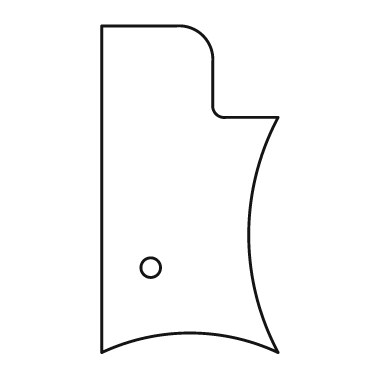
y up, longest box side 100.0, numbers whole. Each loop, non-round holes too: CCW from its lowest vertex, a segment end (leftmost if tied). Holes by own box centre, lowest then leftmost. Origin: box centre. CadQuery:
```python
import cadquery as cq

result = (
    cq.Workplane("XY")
    .moveTo(-27.0, -50.0)
    .threePointArc((0.0, -44.0), (27.0, -50.0))
    .threePointArc((18.0, -14.0), (27.0, 22.0))
    .lineTo(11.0, 22.0)
    .threePointArc((8.0, 23.0), (7.0, 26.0))
    .lineTo(7.0, 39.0)
    .threePointArc((4.0, 47.0), (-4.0, 50.0))
    .lineTo(-27.0, 50.0)
    .close()
    .moveTo(-12.0, -24.0)
    .circle(3.0)
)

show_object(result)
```